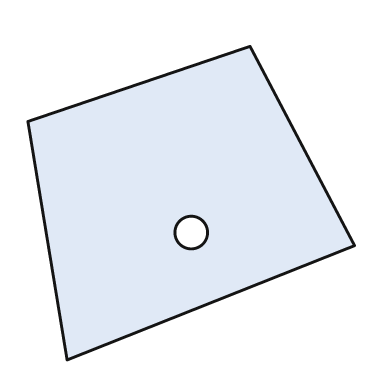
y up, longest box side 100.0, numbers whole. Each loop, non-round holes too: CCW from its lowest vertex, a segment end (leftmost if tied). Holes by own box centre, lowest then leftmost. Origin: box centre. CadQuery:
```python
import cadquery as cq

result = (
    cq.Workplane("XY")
    .moveTo(-38.0, -48.0)
    .lineTo(50.0, -13.0)
    .lineTo(18.0, 48.0)
    .lineTo(-50.0, 25.0)
    .close()
    .moveTo(0.0, -9.0)
    .circle(5.0)
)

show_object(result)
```